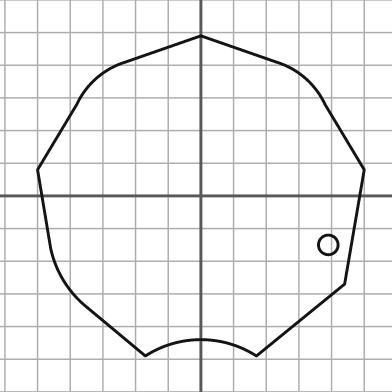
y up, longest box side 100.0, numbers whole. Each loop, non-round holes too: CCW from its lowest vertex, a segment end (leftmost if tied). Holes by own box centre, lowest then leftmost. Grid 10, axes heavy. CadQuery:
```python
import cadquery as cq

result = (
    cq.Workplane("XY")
    .moveTo(-17.0, -49.0)
    .threePointArc((0.0, -44.0), (17.0, -49.0))
    .lineTo(44.0, -27.0)
    .lineTo(50.0, 8.0)
    .lineTo(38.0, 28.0)
    .threePointArc((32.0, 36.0), (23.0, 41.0))
    .lineTo(0.0, 49.0)
    .lineTo(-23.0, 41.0)
    .threePointArc((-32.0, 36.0), (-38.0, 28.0))
    .lineTo(-50.0, 8.0)
    .lineTo(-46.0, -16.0)
    .threePointArc((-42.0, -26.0), (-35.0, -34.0))
    .close()
    .moveTo(39.0, -15.0)
    .circle(3.0)
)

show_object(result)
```